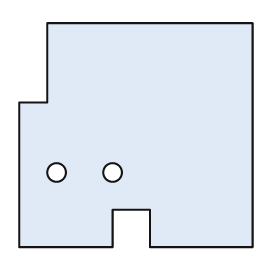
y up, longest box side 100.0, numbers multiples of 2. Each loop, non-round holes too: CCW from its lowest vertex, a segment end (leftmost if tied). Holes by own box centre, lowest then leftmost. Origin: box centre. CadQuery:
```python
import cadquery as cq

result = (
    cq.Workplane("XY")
    .moveTo(-50.0, -48.0)
    .lineTo(-10.0, -48.0)
    .lineTo(-10.0, -32.0)
    .lineTo(6.0, -32.0)
    .lineTo(6.0, -48.0)
    .lineTo(50.0, -48.0)
    .lineTo(50.0, 48.0)
    .lineTo(-38.0, 48.0)
    .lineTo(-38.0, 14.0)
    .lineTo(-50.0, 14.0)
    .close()
    .moveTo(-34.0, -16.0)
    .circle(4.0)
    .moveTo(-10.0, -16.0)
    .circle(4.0)
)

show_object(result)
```